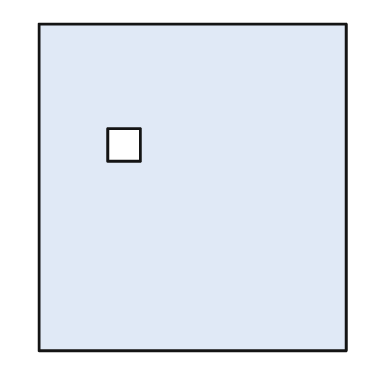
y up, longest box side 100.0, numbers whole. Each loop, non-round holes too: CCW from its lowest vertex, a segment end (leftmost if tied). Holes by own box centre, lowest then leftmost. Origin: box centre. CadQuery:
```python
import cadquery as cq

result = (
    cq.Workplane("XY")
    .moveTo(-47.0, -50.0)
    .lineTo(47.0, -50.0)
    .lineTo(47.0, 50.0)
    .lineTo(-47.0, 50.0)
    .close()
    .moveTo(-26.0, 8.0)
    .lineTo(-16.0, 8.0)
    .lineTo(-16.0, 18.0)
    .lineTo(-26.0, 18.0)
    .close()
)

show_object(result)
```